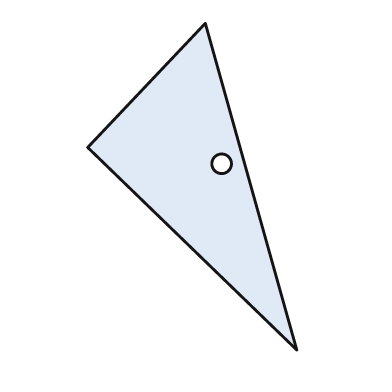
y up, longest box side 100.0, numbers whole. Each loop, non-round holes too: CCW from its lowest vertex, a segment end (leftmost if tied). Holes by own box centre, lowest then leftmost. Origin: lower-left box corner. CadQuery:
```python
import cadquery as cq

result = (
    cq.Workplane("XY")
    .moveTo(64.0, 0.0)
    .lineTo(36.0, 100.0)
    .lineTo(0.0, 62.0)
    .close()
    .moveTo(41.0, 57.0)
    .circle(3.0)
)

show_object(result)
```